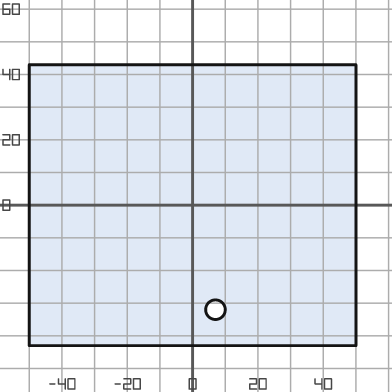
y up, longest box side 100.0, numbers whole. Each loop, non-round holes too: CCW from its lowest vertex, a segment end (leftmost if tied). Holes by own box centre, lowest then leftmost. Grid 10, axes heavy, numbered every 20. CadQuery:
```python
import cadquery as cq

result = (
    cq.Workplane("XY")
    .moveTo(-50.0, -43.0)
    .lineTo(50.0, -43.0)
    .lineTo(50.0, 43.0)
    .lineTo(-50.0, 43.0)
    .close()
    .moveTo(7.0, -32.0)
    .circle(3.0)
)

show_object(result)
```